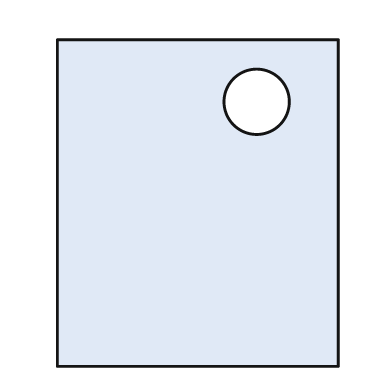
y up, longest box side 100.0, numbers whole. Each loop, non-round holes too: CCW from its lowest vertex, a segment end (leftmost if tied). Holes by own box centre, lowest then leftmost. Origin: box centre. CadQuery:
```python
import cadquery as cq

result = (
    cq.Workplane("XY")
    .moveTo(-43.0, -50.0)
    .lineTo(43.0, -50.0)
    .lineTo(43.0, 50.0)
    .lineTo(-43.0, 50.0)
    .close()
    .moveTo(18.0, 31.0)
    .circle(10.0)
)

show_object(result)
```